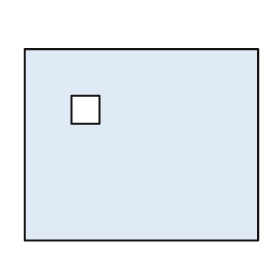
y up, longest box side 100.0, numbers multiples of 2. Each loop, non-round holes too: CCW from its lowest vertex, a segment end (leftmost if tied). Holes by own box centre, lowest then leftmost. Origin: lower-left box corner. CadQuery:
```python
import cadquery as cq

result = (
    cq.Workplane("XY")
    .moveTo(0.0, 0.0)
    .lineTo(100.0, 0.0)
    .lineTo(100.0, 82.0)
    .lineTo(0.0, 82.0)
    .close()
    .moveTo(20.0, 50.0)
    .lineTo(32.0, 50.0)
    .lineTo(32.0, 62.0)
    .lineTo(20.0, 62.0)
    .close()
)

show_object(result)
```